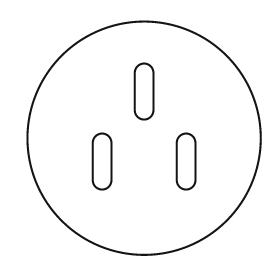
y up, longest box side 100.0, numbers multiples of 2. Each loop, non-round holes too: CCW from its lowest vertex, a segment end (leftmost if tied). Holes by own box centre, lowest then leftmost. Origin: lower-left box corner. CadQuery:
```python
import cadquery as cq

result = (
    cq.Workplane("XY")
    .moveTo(50.0, 50.0)
    .circle(50.0)
    .moveTo(28.0, 32.0)
    .threePointArc((32.0, 28.0), (36.0, 32.0))
    .lineTo(36.0, 48.0)
    .threePointArc((32.0, 52.0), (28.0, 48.0))
    .close()
    .moveTo(64.0, 32.0)
    .threePointArc((68.0, 28.0), (72.0, 32.0))
    .lineTo(72.0, 48.0)
    .threePointArc((68.0, 52.0), (64.0, 48.0))
    .close()
    .moveTo(46.0, 62.0)
    .threePointArc((50.0, 58.0), (54.0, 62.0))
    .lineTo(54.0, 78.0)
    .threePointArc((50.0, 82.0), (46.0, 78.0))
    .close()
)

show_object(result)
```